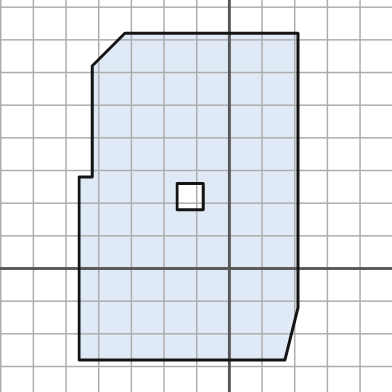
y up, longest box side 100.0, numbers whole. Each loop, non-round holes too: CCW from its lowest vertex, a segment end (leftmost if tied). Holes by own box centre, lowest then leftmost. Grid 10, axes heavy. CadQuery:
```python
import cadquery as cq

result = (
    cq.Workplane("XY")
    .moveTo(-46.0, -28.0)
    .lineTo(17.0, -28.0)
    .lineTo(21.0, -12.0)
    .lineTo(21.0, 72.0)
    .lineTo(-32.0, 72.0)
    .lineTo(-42.0, 62.0)
    .lineTo(-42.0, 28.0)
    .lineTo(-46.0, 28.0)
    .close()
    .moveTo(-16.0, 18.0)
    .lineTo(-8.0, 18.0)
    .lineTo(-8.0, 26.0)
    .lineTo(-16.0, 26.0)
    .close()
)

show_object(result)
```